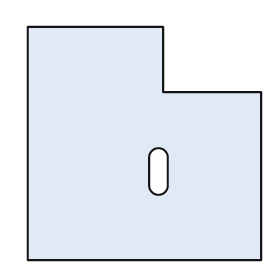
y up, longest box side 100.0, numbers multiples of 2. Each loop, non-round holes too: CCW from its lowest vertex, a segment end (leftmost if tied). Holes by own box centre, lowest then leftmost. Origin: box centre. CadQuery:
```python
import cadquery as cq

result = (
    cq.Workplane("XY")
    .moveTo(-50.0, -50.0)
    .lineTo(50.0, -50.0)
    .lineTo(50.0, 22.0)
    .lineTo(8.0, 22.0)
    .lineTo(8.0, 50.0)
    .lineTo(-50.0, 50.0)
    .close()
    .moveTo(2.0, -18.0)
    .threePointArc((6.0, -22.0), (10.0, -18.0))
    .lineTo(10.0, -6.0)
    .threePointArc((6.0, -2.0), (2.0, -6.0))
    .close()
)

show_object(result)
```